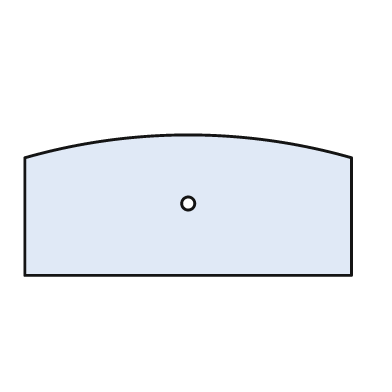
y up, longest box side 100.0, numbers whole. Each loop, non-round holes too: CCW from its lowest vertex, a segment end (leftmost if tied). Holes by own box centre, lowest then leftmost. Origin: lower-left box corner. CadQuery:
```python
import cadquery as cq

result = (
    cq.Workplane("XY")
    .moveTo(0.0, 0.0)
    .lineTo(100.0, 0.0)
    .lineTo(100.0, 36.0)
    .threePointArc((50.0, 43.0), (0.0, 36.0))
    .close()
    .moveTo(50.0, 22.0)
    .circle(2.0)
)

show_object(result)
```